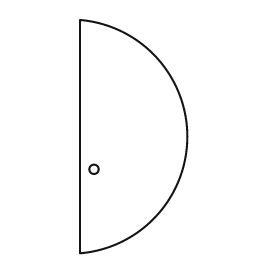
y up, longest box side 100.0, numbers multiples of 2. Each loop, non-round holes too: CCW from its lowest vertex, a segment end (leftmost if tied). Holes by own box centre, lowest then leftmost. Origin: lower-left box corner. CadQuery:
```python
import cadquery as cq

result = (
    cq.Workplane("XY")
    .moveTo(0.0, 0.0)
    .threePointArc((46.0, 50.0), (0.0, 100.0))
    .close()
    .moveTo(6.0, 36.0)
    .circle(2.0)
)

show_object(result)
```